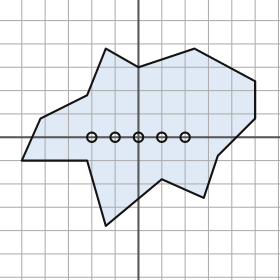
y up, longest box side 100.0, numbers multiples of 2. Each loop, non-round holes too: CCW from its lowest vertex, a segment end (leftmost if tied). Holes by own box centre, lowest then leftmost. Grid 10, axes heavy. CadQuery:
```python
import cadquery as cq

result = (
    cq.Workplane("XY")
    .moveTo(-14.0, -38.0)
    .lineTo(10.0, -18.0)
    .lineTo(28.0, -26.0)
    .lineTo(34.0, -8.0)
    .lineTo(50.0, 8.0)
    .lineTo(50.0, 24.0)
    .lineTo(24.0, 38.0)
    .lineTo(0.0, 30.0)
    .lineTo(-14.0, 38.0)
    .lineTo(-22.0, 18.0)
    .lineTo(-42.0, 8.0)
    .lineTo(-50.0, -10.0)
    .lineTo(-22.0, -10.0)
    .close()
    .moveTo(-20.0, 0.0)
    .circle(2.0)
    .moveTo(-10.0, 0.0)
    .circle(2.0)
    .moveTo(0.0, 0.0)
    .circle(2.0)
    .moveTo(10.0, 0.0)
    .circle(2.0)
    .moveTo(20.0, 0.0)
    .circle(2.0)
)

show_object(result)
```